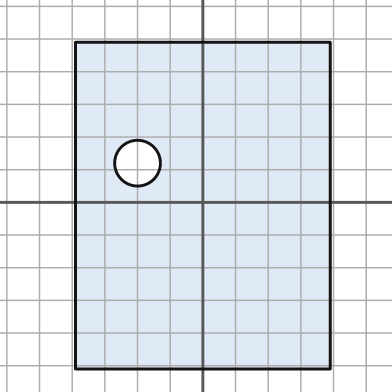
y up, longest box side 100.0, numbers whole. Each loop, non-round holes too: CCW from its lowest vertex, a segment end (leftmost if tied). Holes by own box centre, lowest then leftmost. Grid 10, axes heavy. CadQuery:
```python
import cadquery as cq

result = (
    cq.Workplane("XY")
    .moveTo(-39.0, -51.0)
    .lineTo(39.0, -51.0)
    .lineTo(39.0, 49.0)
    .lineTo(-39.0, 49.0)
    .close()
    .moveTo(-20.0, 12.0)
    .circle(7.0)
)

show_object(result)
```